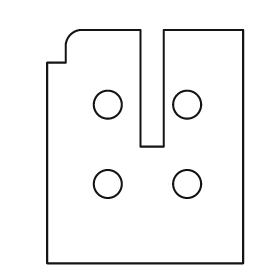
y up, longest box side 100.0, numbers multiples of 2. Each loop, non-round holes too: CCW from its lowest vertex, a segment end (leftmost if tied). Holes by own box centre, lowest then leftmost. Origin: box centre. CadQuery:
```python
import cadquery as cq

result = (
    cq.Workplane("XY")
    .moveTo(-42.0, -50.0)
    .lineTo(42.0, -50.0)
    .lineTo(42.0, 50.0)
    .lineTo(8.0, 50.0)
    .lineTo(8.0, 0.0)
    .lineTo(-2.0, 0.0)
    .lineTo(-2.0, 50.0)
    .lineTo(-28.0, 50.0)
    .threePointArc((-32.0, 48.0), (-34.0, 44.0))
    .lineTo(-34.0, 36.0)
    .lineTo(-42.0, 36.0)
    .close()
    .moveTo(-16.0, -16.0)
    .circle(6.0)
    .moveTo(18.0, -16.0)
    .circle(6.0)
    .moveTo(-16.0, 18.0)
    .circle(6.0)
    .moveTo(18.0, 18.0)
    .circle(6.0)
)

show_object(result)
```